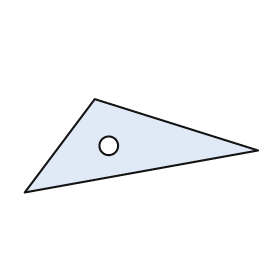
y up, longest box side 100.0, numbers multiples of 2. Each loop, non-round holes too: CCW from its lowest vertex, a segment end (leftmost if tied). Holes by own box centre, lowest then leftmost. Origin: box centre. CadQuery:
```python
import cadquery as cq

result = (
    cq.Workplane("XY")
    .moveTo(-50.0, -20.0)
    .lineTo(50.0, -2.0)
    .lineTo(-20.0, 20.0)
    .close()
    .moveTo(-14.0, 0.0)
    .circle(4.0)
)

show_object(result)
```